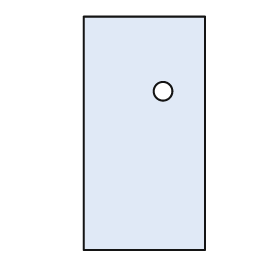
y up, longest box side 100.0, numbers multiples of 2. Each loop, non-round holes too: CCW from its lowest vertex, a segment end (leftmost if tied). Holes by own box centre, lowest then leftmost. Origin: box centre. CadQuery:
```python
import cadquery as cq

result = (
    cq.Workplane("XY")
    .moveTo(-26.0, -50.0)
    .lineTo(26.0, -50.0)
    .lineTo(26.0, 50.0)
    .lineTo(-26.0, 50.0)
    .close()
    .moveTo(8.0, 18.0)
    .circle(4.0)
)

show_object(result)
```